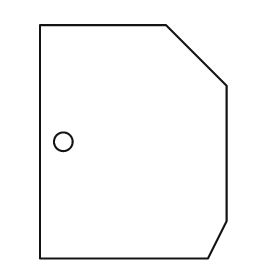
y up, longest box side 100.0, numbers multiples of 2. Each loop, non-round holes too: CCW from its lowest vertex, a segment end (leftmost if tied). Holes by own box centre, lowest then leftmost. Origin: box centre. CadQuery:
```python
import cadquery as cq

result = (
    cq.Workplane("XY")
    .moveTo(-40.0, -50.0)
    .lineTo(32.0, -50.0)
    .lineTo(40.0, -34.0)
    .lineTo(40.0, 24.0)
    .lineTo(14.0, 50.0)
    .lineTo(-40.0, 50.0)
    .close()
    .moveTo(-30.0, 0.0)
    .circle(4.0)
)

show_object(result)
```